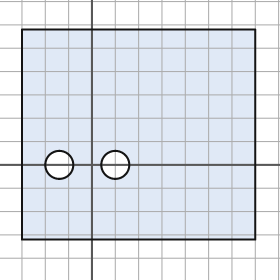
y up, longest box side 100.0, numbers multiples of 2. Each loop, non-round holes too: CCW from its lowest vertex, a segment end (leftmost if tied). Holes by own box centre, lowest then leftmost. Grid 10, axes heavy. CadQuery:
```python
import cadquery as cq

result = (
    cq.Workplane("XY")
    .moveTo(-30.0, -32.0)
    .lineTo(70.0, -32.0)
    .lineTo(70.0, 58.0)
    .lineTo(-30.0, 58.0)
    .close()
    .moveTo(-14.0, 0.0)
    .circle(6.0)
    .moveTo(10.0, 0.0)
    .circle(6.0)
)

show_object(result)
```